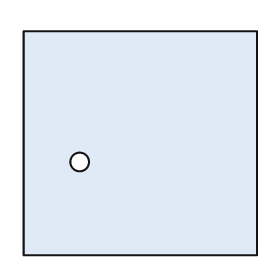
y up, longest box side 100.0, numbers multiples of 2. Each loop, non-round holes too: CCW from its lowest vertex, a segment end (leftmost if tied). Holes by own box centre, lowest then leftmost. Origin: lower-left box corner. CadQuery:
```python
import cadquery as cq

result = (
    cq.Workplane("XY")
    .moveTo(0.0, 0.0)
    .lineTo(100.0, 0.0)
    .lineTo(100.0, 96.0)
    .lineTo(0.0, 96.0)
    .close()
    .moveTo(24.0, 40.0)
    .circle(4.0)
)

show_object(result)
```